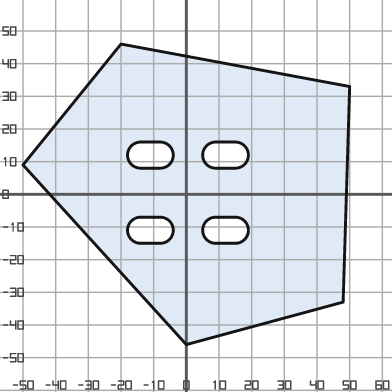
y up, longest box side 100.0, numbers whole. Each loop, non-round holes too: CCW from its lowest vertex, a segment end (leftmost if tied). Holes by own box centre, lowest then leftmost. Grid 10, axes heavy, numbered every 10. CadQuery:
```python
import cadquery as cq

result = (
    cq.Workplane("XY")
    .moveTo(0.0, -46.0)
    .lineTo(48.0, -33.0)
    .lineTo(50.0, 33.0)
    .lineTo(-20.0, 46.0)
    .lineTo(-50.0, 9.0)
    .close()
    .moveTo(-14.0, -15.0)
    .lineTo(-8.0, -15.0)
    .threePointArc((-4.0, -11.0), (-8.0, -7.0))
    .lineTo(-14.0, -7.0)
    .threePointArc((-18.0, -11.0), (-14.0, -15.0))
    .close()
    .moveTo(9.0, -15.0)
    .lineTo(15.0, -15.0)
    .threePointArc((19.0, -11.0), (15.0, -7.0))
    .lineTo(9.0, -7.0)
    .threePointArc((5.0, -11.0), (9.0, -15.0))
    .close()
    .moveTo(-14.0, 8.0)
    .lineTo(-8.0, 8.0)
    .threePointArc((-4.0, 12.0), (-8.0, 16.0))
    .lineTo(-14.0, 16.0)
    .threePointArc((-18.0, 12.0), (-14.0, 8.0))
    .close()
    .moveTo(9.0, 8.0)
    .lineTo(15.0, 8.0)
    .threePointArc((19.0, 12.0), (15.0, 16.0))
    .lineTo(9.0, 16.0)
    .threePointArc((5.0, 12.0), (9.0, 8.0))
    .close()
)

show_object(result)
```